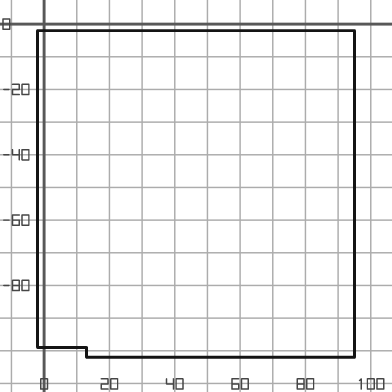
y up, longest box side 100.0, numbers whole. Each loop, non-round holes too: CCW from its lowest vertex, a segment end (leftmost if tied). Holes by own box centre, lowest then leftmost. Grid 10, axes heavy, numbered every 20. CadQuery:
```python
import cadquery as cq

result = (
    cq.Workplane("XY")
    .moveTo(13.0, -102.0)
    .lineTo(95.0, -102.0)
    .lineTo(95.0, -2.0)
    .lineTo(-2.0, -2.0)
    .lineTo(-2.0, -99.0)
    .lineTo(13.0, -99.0)
    .close()
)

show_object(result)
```